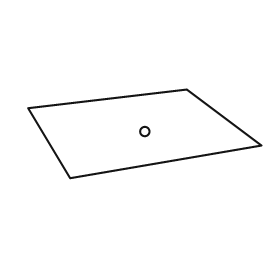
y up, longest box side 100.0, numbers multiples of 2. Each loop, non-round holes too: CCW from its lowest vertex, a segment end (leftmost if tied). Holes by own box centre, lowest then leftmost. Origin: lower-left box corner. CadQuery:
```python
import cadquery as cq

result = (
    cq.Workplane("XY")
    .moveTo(18.0, 0.0)
    .lineTo(100.0, 14.0)
    .lineTo(68.0, 38.0)
    .lineTo(0.0, 30.0)
    .close()
    .moveTo(50.0, 20.0)
    .circle(2.0)
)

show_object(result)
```